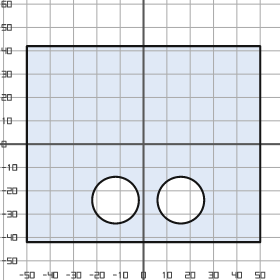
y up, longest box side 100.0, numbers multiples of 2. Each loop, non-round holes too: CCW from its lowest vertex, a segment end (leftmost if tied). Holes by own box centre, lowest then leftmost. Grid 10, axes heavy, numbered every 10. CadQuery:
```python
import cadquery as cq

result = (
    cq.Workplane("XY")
    .moveTo(-50.0, -42.0)
    .lineTo(50.0, -42.0)
    .lineTo(50.0, 42.0)
    .lineTo(-50.0, 42.0)
    .close()
    .moveTo(-12.0, -24.0)
    .circle(10.0)
    .moveTo(16.0, -24.0)
    .circle(10.0)
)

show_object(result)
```